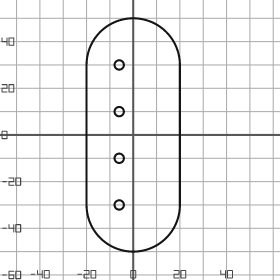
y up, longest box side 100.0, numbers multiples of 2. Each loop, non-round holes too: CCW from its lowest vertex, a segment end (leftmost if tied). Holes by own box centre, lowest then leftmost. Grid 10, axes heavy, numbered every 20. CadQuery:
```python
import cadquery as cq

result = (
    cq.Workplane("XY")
    .moveTo(-20.0, -30.0)
    .threePointArc((0.0, -50.0), (20.0, -30.0))
    .lineTo(20.0, 30.0)
    .threePointArc((0.0, 50.0), (-20.0, 30.0))
    .close()
    .moveTo(-6.0, -30.0)
    .circle(2.0)
    .moveTo(-6.0, -10.0)
    .circle(2.0)
    .moveTo(-6.0, 10.0)
    .circle(2.0)
    .moveTo(-6.0, 30.0)
    .circle(2.0)
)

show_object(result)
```